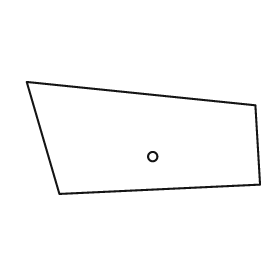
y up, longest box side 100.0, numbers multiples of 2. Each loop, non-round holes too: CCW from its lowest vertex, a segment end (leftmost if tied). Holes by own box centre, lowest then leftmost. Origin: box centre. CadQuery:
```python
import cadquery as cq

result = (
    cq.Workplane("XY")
    .moveTo(-36.0, -24.0)
    .lineTo(50.0, -20.0)
    .lineTo(48.0, 14.0)
    .lineTo(-50.0, 24.0)
    .close()
    .moveTo(4.0, -8.0)
    .circle(2.0)
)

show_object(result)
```